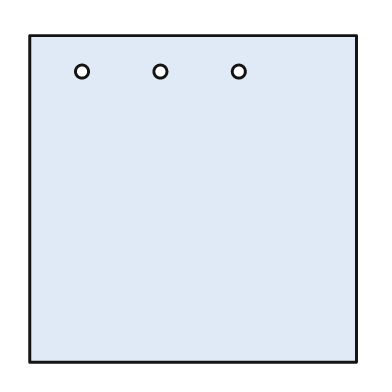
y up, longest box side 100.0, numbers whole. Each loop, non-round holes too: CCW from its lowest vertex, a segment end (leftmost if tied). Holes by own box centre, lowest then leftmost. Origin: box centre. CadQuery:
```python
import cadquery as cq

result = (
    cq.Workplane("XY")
    .moveTo(-50.0, -50.0)
    .lineTo(50.0, -50.0)
    .lineTo(50.0, 50.0)
    .lineTo(-50.0, 50.0)
    .close()
    .moveTo(-34.0, 39.0)
    .circle(2.0)
    .moveTo(-10.0, 39.0)
    .circle(2.0)
    .moveTo(14.0, 39.0)
    .circle(2.0)
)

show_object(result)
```